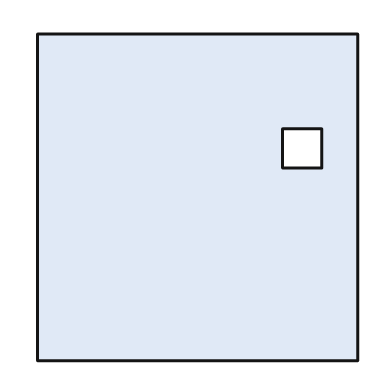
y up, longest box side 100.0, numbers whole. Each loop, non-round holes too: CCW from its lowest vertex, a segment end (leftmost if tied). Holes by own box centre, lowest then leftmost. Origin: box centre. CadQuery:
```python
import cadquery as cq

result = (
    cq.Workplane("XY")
    .moveTo(-49.0, -50.0)
    .lineTo(49.0, -50.0)
    .lineTo(49.0, 50.0)
    .lineTo(-49.0, 50.0)
    .close()
    .moveTo(26.0, 9.0)
    .lineTo(38.0, 9.0)
    .lineTo(38.0, 21.0)
    .lineTo(26.0, 21.0)
    .close()
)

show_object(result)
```